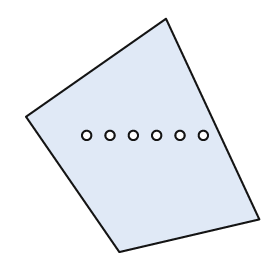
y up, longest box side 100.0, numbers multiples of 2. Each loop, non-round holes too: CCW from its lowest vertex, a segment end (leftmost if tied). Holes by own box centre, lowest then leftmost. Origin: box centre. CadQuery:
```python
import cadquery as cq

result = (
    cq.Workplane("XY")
    .moveTo(-10.0, -50.0)
    .lineTo(50.0, -36.0)
    .lineTo(10.0, 50.0)
    .lineTo(-50.0, 8.0)
    .close()
    .moveTo(-24.0, 0.0)
    .circle(2.0)
    .moveTo(-14.0, 0.0)
    .circle(2.0)
    .moveTo(-4.0, 0.0)
    .circle(2.0)
    .moveTo(6.0, 0.0)
    .circle(2.0)
    .moveTo(16.0, 0.0)
    .circle(2.0)
    .moveTo(26.0, 0.0)
    .circle(2.0)
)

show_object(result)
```